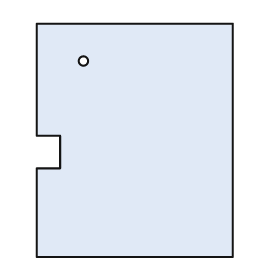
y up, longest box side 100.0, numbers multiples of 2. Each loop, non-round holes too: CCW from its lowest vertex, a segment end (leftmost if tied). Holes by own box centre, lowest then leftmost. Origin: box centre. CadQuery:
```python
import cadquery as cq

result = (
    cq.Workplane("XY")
    .moveTo(-42.0, -50.0)
    .lineTo(42.0, -50.0)
    .lineTo(42.0, 50.0)
    .lineTo(-42.0, 50.0)
    .lineTo(-42.0, 2.0)
    .lineTo(-32.0, 2.0)
    .lineTo(-32.0, -12.0)
    .lineTo(-42.0, -12.0)
    .close()
    .moveTo(-22.0, 34.0)
    .circle(2.0)
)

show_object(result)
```